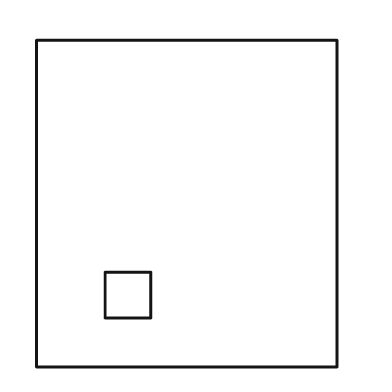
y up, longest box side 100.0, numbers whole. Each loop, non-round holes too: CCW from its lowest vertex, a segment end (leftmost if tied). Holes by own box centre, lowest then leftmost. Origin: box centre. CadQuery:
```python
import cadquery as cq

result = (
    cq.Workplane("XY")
    .moveTo(-46.0, -50.0)
    .lineTo(46.0, -50.0)
    .lineTo(46.0, 50.0)
    .lineTo(-46.0, 50.0)
    .close()
    .moveTo(-25.0, -35.0)
    .lineTo(-11.0, -35.0)
    .lineTo(-11.0, -21.0)
    .lineTo(-25.0, -21.0)
    .close()
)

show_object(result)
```